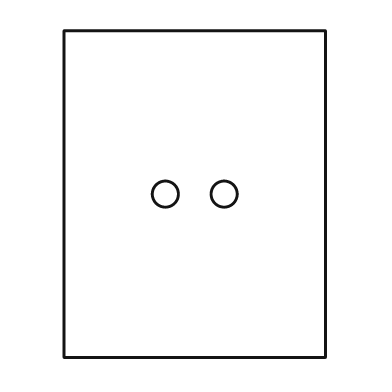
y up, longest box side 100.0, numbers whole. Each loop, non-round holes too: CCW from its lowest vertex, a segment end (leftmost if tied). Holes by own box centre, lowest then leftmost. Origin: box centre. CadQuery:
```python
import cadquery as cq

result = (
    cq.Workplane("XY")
    .moveTo(-40.0, -50.0)
    .lineTo(40.0, -50.0)
    .lineTo(40.0, 50.0)
    .lineTo(-40.0, 50.0)
    .close()
    .moveTo(-9.0, 0.0)
    .circle(4.0)
    .moveTo(9.0, 0.0)
    .circle(4.0)
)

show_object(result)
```